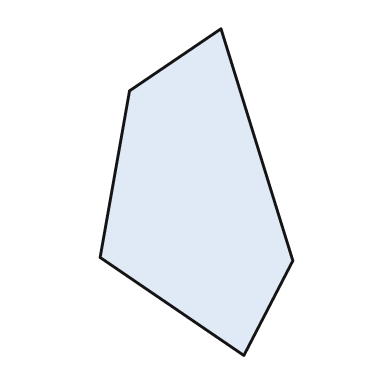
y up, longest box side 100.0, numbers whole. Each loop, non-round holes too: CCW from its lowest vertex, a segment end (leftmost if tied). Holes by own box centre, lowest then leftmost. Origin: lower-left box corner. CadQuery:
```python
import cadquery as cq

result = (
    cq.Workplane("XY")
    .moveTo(44.0, 0.0)
    .lineTo(59.0, 29.0)
    .lineTo(37.0, 100.0)
    .lineTo(9.0, 81.0)
    .lineTo(0.0, 30.0)
    .close()
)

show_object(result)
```